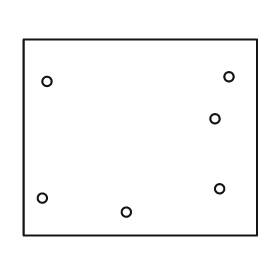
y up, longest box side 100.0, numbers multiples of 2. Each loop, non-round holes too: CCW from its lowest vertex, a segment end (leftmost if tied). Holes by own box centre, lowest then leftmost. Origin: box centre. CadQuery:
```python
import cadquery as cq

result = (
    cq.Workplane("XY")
    .moveTo(-50.0, -42.0)
    .lineTo(50.0, -42.0)
    .lineTo(50.0, 42.0)
    .lineTo(-50.0, 42.0)
    .close()
    .moveTo(-6.0, -32.0)
    .circle(2.0)
    .moveTo(-42.0, -26.0)
    .circle(2.0)
    .moveTo(34.0, -22.0)
    .circle(2.0)
    .moveTo(32.0, 8.0)
    .circle(2.0)
    .moveTo(-40.0, 24.0)
    .circle(2.0)
    .moveTo(38.0, 26.0)
    .circle(2.0)
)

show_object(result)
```